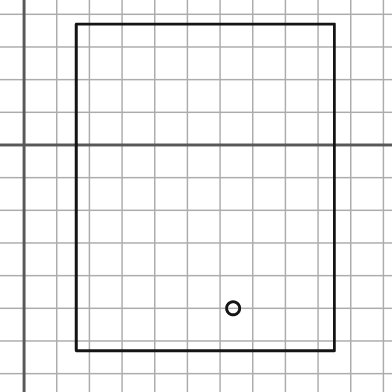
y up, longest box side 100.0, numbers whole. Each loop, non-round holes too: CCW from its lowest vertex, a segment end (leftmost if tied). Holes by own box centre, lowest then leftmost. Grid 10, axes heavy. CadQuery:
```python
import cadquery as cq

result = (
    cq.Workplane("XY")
    .moveTo(16.0, -63.0)
    .lineTo(95.0, -63.0)
    .lineTo(95.0, 37.0)
    .lineTo(16.0, 37.0)
    .close()
    .moveTo(64.0, -50.0)
    .circle(2.0)
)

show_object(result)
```